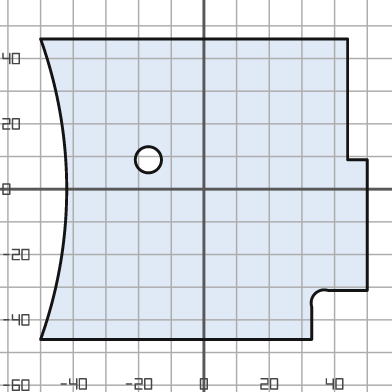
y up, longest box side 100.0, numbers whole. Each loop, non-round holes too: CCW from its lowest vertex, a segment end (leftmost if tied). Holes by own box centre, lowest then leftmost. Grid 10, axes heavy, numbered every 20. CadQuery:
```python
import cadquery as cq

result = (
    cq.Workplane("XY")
    .moveTo(-50.0, -46.0)
    .lineTo(33.0, -46.0)
    .lineTo(33.0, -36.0)
    .threePointArc((34.0, -32.0), (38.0, -31.0))
    .lineTo(50.0, -31.0)
    .lineTo(50.0, 9.0)
    .lineTo(44.0, 9.0)
    .lineTo(44.0, 46.0)
    .lineTo(-50.0, 46.0)
    .threePointArc((-42.0, 0.0), (-50.0, -46.0))
    .close()
    .moveTo(-17.0, 9.0)
    .circle(4.0)
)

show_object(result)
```